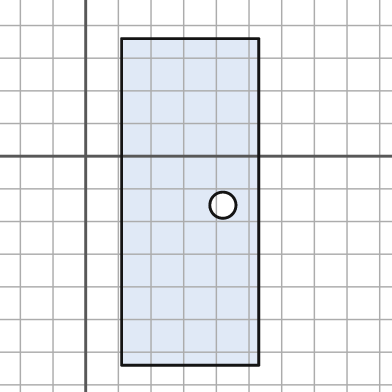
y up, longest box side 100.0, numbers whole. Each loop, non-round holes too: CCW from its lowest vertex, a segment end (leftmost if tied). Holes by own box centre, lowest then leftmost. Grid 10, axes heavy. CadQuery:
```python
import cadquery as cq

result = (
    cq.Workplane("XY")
    .moveTo(11.0, -64.0)
    .lineTo(53.0, -64.0)
    .lineTo(53.0, 36.0)
    .lineTo(11.0, 36.0)
    .close()
    .moveTo(42.0, -15.0)
    .circle(4.0)
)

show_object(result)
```